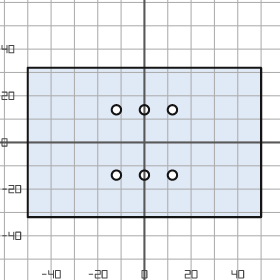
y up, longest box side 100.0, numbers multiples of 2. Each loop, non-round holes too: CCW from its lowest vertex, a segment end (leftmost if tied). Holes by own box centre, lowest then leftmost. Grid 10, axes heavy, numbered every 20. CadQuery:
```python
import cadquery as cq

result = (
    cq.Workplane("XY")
    .moveTo(-50.0, -32.0)
    .lineTo(50.0, -32.0)
    .lineTo(50.0, 32.0)
    .lineTo(-50.0, 32.0)
    .close()
    .moveTo(-12.0, -14.0)
    .circle(2.0)
    .moveTo(0.0, -14.0)
    .circle(2.0)
    .moveTo(12.0, -14.0)
    .circle(2.0)
    .moveTo(-12.0, 14.0)
    .circle(2.0)
    .moveTo(0.0, 14.0)
    .circle(2.0)
    .moveTo(12.0, 14.0)
    .circle(2.0)
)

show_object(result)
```